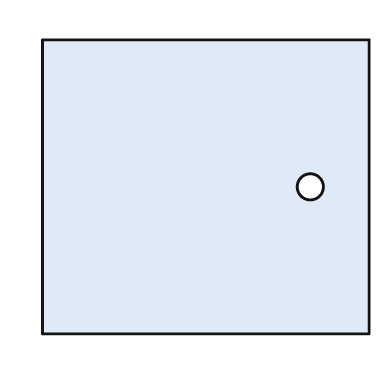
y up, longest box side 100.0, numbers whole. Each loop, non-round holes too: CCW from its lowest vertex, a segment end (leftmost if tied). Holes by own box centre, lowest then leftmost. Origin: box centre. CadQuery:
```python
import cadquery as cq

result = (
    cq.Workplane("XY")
    .moveTo(-50.0, -45.0)
    .lineTo(50.0, -45.0)
    .lineTo(50.0, 45.0)
    .lineTo(-50.0, 45.0)
    .close()
    .moveTo(32.0, 0.0)
    .circle(4.0)
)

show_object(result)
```